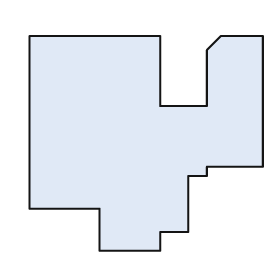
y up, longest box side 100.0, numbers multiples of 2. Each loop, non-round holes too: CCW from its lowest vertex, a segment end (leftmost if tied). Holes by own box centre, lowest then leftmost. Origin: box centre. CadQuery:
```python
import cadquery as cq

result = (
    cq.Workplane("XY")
    .moveTo(-20.0, -46.0)
    .lineTo(6.0, -46.0)
    .lineTo(6.0, -38.0)
    .lineTo(18.0, -38.0)
    .lineTo(18.0, -14.0)
    .lineTo(26.0, -14.0)
    .lineTo(26.0, -10.0)
    .lineTo(50.0, -10.0)
    .lineTo(50.0, 46.0)
    .lineTo(32.0, 46.0)
    .lineTo(26.0, 40.0)
    .lineTo(26.0, 16.0)
    .lineTo(6.0, 16.0)
    .lineTo(6.0, 46.0)
    .lineTo(-50.0, 46.0)
    .lineTo(-50.0, -28.0)
    .lineTo(-20.0, -28.0)
    .close()
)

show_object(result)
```